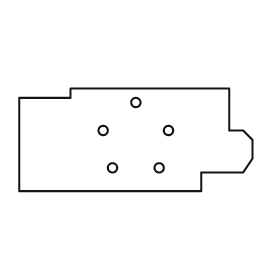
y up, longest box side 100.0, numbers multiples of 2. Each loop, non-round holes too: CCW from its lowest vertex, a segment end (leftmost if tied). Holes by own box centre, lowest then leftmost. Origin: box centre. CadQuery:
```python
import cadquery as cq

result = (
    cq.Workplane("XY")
    .moveTo(-50.0, -22.0)
    .lineTo(28.0, -22.0)
    .lineTo(28.0, -14.0)
    .lineTo(46.0, -14.0)
    .lineTo(50.0, -8.0)
    .lineTo(50.0, 0.0)
    .lineTo(46.0, 4.0)
    .lineTo(40.0, 4.0)
    .lineTo(40.0, 22.0)
    .lineTo(-28.0, 22.0)
    .lineTo(-28.0, 18.0)
    .lineTo(-50.0, 18.0)
    .close()
    .moveTo(-10.0, -12.0)
    .circle(2.0)
    .moveTo(10.0, -12.0)
    .circle(2.0)
    .moveTo(-14.0, 4.0)
    .circle(2.0)
    .moveTo(14.0, 4.0)
    .circle(2.0)
    .moveTo(0.0, 16.0)
    .circle(2.0)
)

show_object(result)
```